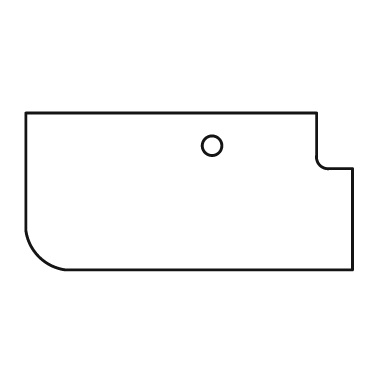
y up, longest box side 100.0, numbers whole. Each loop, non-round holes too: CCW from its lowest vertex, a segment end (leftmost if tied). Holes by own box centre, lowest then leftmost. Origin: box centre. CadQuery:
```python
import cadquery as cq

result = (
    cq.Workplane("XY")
    .moveTo(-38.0, -24.0)
    .lineTo(50.0, -24.0)
    .lineTo(50.0, 7.0)
    .lineTo(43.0, 7.0)
    .threePointArc((40.0, 8.0), (39.0, 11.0))
    .lineTo(39.0, 24.0)
    .lineTo(-50.0, 24.0)
    .lineTo(-50.0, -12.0)
    .threePointArc((-46.0, -20.0), (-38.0, -24.0))
    .close()
    .moveTo(7.0, 14.0)
    .circle(3.0)
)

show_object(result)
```